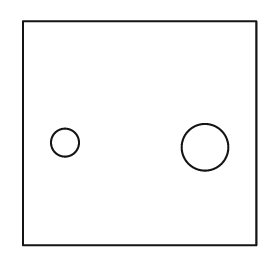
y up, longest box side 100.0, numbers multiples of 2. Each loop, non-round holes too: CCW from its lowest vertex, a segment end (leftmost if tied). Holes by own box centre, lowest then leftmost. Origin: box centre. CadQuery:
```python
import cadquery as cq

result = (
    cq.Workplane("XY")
    .moveTo(-50.0, -48.0)
    .lineTo(50.0, -48.0)
    .lineTo(50.0, 48.0)
    .lineTo(-50.0, 48.0)
    .close()
    .moveTo(28.0, -6.0)
    .circle(10.0)
    .moveTo(-32.0, -4.0)
    .circle(6.0)
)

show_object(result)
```